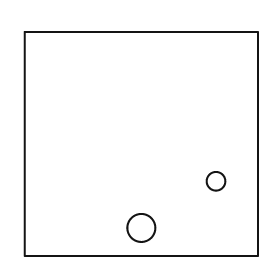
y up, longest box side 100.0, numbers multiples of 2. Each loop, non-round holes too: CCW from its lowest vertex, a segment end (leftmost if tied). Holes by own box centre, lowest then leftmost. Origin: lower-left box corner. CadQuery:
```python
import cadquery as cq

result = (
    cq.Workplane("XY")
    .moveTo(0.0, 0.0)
    .lineTo(100.0, 0.0)
    .lineTo(100.0, 96.0)
    .lineTo(0.0, 96.0)
    .close()
    .moveTo(50.0, 12.0)
    .circle(6.0)
    .moveTo(82.0, 32.0)
    .circle(4.0)
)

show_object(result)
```